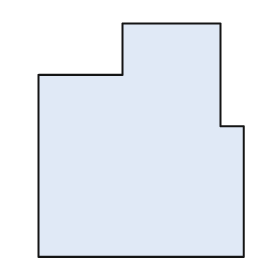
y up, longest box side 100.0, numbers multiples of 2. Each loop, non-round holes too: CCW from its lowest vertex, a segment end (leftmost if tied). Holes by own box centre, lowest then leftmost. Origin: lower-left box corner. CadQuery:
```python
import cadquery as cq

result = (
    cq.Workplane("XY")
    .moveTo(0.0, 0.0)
    .lineTo(88.0, 0.0)
    .lineTo(88.0, 56.0)
    .lineTo(78.0, 56.0)
    .lineTo(78.0, 100.0)
    .lineTo(36.0, 100.0)
    .lineTo(36.0, 78.0)
    .lineTo(0.0, 78.0)
    .close()
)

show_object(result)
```